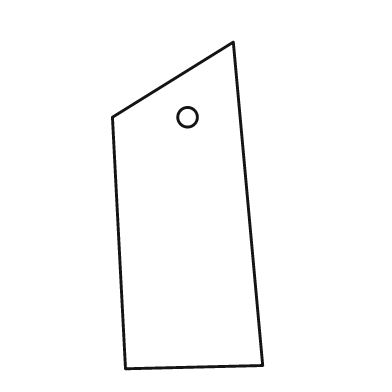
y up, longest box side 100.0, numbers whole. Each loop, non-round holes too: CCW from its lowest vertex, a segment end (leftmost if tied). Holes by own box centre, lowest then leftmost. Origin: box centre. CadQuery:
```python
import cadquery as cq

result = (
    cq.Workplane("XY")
    .moveTo(-19.0, -50.0)
    .lineTo(23.0, -49.0)
    .lineTo(14.0, 50.0)
    .lineTo(-23.0, 27.0)
    .close()
    .moveTo(0.0, 27.0)
    .circle(3.0)
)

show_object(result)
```